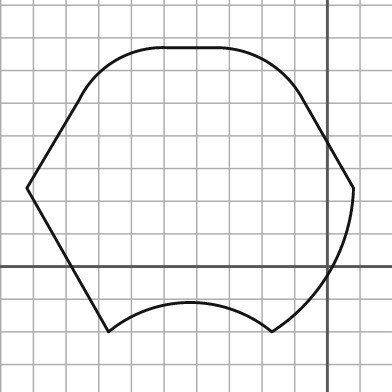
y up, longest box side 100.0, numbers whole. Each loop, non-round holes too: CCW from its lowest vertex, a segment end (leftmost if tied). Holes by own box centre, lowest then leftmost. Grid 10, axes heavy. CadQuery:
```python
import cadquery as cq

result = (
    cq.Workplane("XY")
    .moveTo(-67.0, -20.0)
    .threePointArc((-42.0, -11.0), (-17.0, -20.0))
    .threePointArc((1.0, -1.0), (8.0, 24.0))
    .lineTo(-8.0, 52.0)
    .threePointArc((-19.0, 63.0), (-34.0, 67.0))
    .lineTo(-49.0, 67.0)
    .threePointArc((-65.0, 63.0), (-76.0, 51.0))
    .lineTo(-92.0, 24.0)
    .close()
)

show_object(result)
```